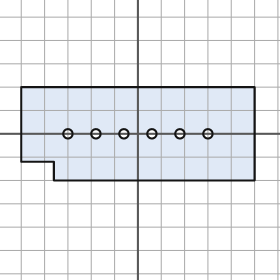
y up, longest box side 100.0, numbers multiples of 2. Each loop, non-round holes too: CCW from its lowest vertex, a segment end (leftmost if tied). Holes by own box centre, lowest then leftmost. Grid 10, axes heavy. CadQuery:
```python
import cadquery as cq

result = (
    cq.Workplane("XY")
    .moveTo(-36.0, -20.0)
    .lineTo(50.0, -20.0)
    .lineTo(50.0, 20.0)
    .lineTo(-50.0, 20.0)
    .lineTo(-50.0, -12.0)
    .lineTo(-36.0, -12.0)
    .close()
    .moveTo(-30.0, 0.0)
    .circle(2.0)
    .moveTo(-18.0, 0.0)
    .circle(2.0)
    .moveTo(-6.0, 0.0)
    .circle(2.0)
    .moveTo(6.0, 0.0)
    .circle(2.0)
    .moveTo(18.0, 0.0)
    .circle(2.0)
    .moveTo(30.0, 0.0)
    .circle(2.0)
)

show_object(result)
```